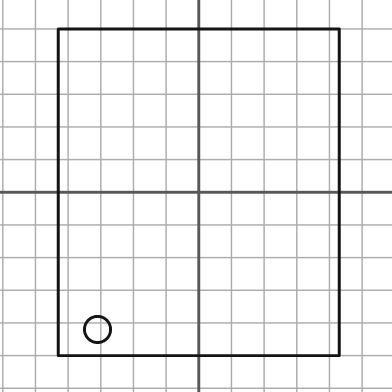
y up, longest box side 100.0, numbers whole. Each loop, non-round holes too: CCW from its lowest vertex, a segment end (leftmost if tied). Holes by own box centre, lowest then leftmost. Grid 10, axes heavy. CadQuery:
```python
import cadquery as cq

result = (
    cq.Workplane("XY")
    .moveTo(-43.0, -50.0)
    .lineTo(43.0, -50.0)
    .lineTo(43.0, 50.0)
    .lineTo(-43.0, 50.0)
    .close()
    .moveTo(-31.0, -42.0)
    .circle(4.0)
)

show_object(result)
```